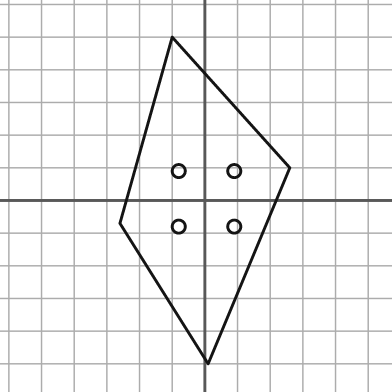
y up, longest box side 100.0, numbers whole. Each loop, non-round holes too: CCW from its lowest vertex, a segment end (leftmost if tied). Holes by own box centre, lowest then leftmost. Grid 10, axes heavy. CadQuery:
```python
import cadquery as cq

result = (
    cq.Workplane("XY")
    .moveTo(1.0, -50.0)
    .lineTo(26.0, 10.0)
    .lineTo(-10.0, 50.0)
    .lineTo(-26.0, -7.0)
    .close()
    .moveTo(-8.0, -8.0)
    .circle(2.0)
    .moveTo(9.0, -8.0)
    .circle(2.0)
    .moveTo(-8.0, 9.0)
    .circle(2.0)
    .moveTo(9.0, 9.0)
    .circle(2.0)
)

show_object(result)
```